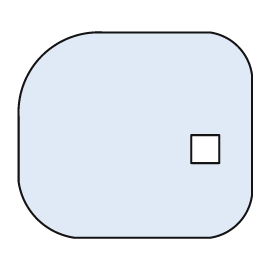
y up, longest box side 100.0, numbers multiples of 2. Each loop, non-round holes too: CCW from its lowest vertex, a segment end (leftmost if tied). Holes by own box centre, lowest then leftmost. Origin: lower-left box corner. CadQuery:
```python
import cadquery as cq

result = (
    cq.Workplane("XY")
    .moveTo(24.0, 0.0)
    .lineTo(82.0, 0.0)
    .threePointArc((94.0, 6.0), (100.0, 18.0))
    .lineTo(100.0, 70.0)
    .threePointArc((94.0, 82.0), (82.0, 88.0))
    .lineTo(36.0, 88.0)
    .threePointArc((10.0, 78.0), (0.0, 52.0))
    .lineTo(0.0, 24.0)
    .threePointArc((8.0, 8.0), (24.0, 0.0))
    .close()
    .moveTo(74.0, 32.0)
    .lineTo(86.0, 32.0)
    .lineTo(86.0, 44.0)
    .lineTo(74.0, 44.0)
    .close()
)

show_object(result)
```